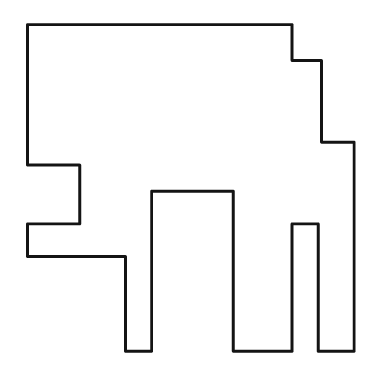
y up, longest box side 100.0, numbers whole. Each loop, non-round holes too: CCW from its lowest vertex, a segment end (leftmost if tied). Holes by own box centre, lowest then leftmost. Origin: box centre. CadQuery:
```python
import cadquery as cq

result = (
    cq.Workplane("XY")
    .moveTo(-20.0, -50.0)
    .lineTo(-12.0, -50.0)
    .lineTo(-12.0, -1.0)
    .lineTo(13.0, -1.0)
    .lineTo(13.0, -50.0)
    .lineTo(31.0, -50.0)
    .lineTo(31.0, -11.0)
    .lineTo(39.0, -11.0)
    .lineTo(39.0, -50.0)
    .lineTo(50.0, -50.0)
    .lineTo(50.0, 14.0)
    .lineTo(40.0, 14.0)
    .lineTo(40.0, 39.0)
    .lineTo(31.0, 39.0)
    .lineTo(31.0, 50.0)
    .lineTo(-50.0, 50.0)
    .lineTo(-50.0, 7.0)
    .lineTo(-34.0, 7.0)
    .lineTo(-34.0, -11.0)
    .lineTo(-50.0, -11.0)
    .lineTo(-50.0, -21.0)
    .lineTo(-20.0, -21.0)
    .close()
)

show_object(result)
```